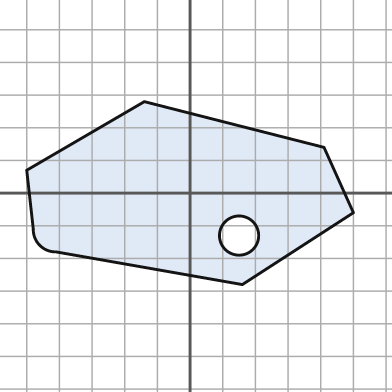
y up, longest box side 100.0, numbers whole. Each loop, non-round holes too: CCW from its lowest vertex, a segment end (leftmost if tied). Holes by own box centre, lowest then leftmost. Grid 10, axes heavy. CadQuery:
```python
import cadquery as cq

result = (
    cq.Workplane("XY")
    .moveTo(16.0, -28.0)
    .lineTo(50.0, -6.0)
    .lineTo(41.0, 14.0)
    .lineTo(-14.0, 28.0)
    .lineTo(-50.0, 7.0)
    .lineTo(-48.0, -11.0)
    .threePointArc((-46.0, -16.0), (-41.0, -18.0))
    .close()
    .moveTo(15.0, -13.0)
    .circle(6.0)
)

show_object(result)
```